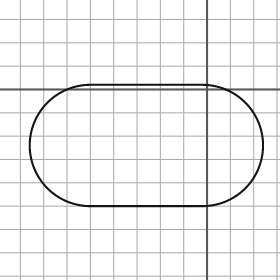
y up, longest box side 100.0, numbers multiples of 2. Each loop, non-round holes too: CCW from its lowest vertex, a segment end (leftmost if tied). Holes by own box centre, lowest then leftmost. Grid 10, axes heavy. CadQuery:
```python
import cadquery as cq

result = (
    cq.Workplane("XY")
    .moveTo(-50.0, -50.0)
    .lineTo(-2.0, -50.0)
    .threePointArc((24.0, -24.0), (-2.0, 2.0))
    .lineTo(-50.0, 2.0)
    .threePointArc((-76.0, -24.0), (-50.0, -50.0))
    .close()
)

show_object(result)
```